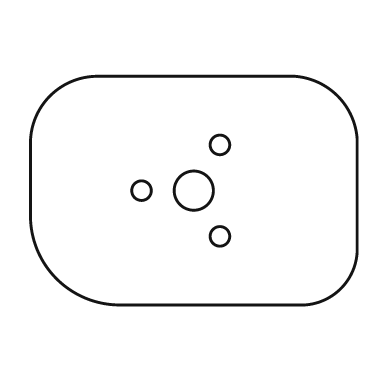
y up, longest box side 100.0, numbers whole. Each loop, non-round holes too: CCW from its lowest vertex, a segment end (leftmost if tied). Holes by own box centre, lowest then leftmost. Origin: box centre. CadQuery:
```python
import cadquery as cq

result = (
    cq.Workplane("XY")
    .moveTo(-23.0, -35.0)
    .lineTo(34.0, -35.0)
    .threePointArc((45.0, -30.0), (50.0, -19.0))
    .lineTo(50.0, 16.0)
    .threePointArc((44.0, 29.0), (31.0, 35.0))
    .lineTo(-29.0, 35.0)
    .threePointArc((-44.0, 29.0), (-50.0, 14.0))
    .lineTo(-50.0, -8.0)
    .threePointArc((-42.0, -27.0), (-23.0, -35.0))
    .close()
    .moveTo(8.0, -14.0)
    .circle(3.0)
    .moveTo(-16.0, 0.0)
    .circle(3.0)
    .moveTo(0.0, 0.0)
    .circle(6.0)
    .moveTo(8.0, 14.0)
    .circle(3.0)
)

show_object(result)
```